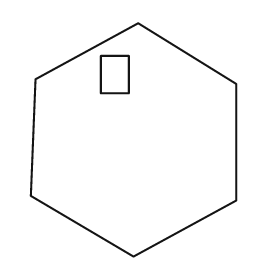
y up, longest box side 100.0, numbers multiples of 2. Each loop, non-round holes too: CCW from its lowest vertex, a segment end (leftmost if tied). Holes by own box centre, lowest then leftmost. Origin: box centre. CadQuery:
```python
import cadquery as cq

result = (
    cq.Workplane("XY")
    .moveTo(0.0, -50.0)
    .lineTo(44.0, -26.0)
    .lineTo(44.0, 24.0)
    .lineTo(2.0, 50.0)
    .lineTo(-42.0, 26.0)
    .lineTo(-44.0, -24.0)
    .close()
    .moveTo(-14.0, 20.0)
    .lineTo(-2.0, 20.0)
    .lineTo(-2.0, 36.0)
    .lineTo(-14.0, 36.0)
    .close()
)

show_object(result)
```